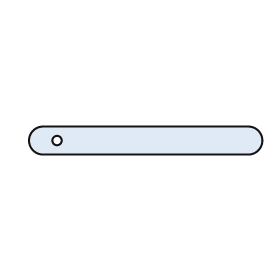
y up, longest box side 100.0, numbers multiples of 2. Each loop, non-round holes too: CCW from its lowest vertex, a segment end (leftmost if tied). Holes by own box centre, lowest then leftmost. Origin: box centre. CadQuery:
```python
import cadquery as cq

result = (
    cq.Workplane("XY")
    .moveTo(-44.0, -6.0)
    .lineTo(44.0, -6.0)
    .threePointArc((50.0, 0.0), (44.0, 6.0))
    .lineTo(-44.0, 6.0)
    .threePointArc((-50.0, 0.0), (-44.0, -6.0))
    .close()
    .moveTo(-38.0, 0.0)
    .circle(2.0)
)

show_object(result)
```